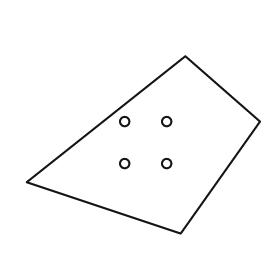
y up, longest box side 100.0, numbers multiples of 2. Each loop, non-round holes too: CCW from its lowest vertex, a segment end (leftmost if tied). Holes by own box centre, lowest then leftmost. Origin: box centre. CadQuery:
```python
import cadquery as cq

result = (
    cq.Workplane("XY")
    .moveTo(16.0, -38.0)
    .lineTo(50.0, 10.0)
    .lineTo(18.0, 38.0)
    .lineTo(-50.0, -16.0)
    .close()
    .moveTo(-8.0, -8.0)
    .circle(2.0)
    .moveTo(10.0, -8.0)
    .circle(2.0)
    .moveTo(-8.0, 10.0)
    .circle(2.0)
    .moveTo(10.0, 10.0)
    .circle(2.0)
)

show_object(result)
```